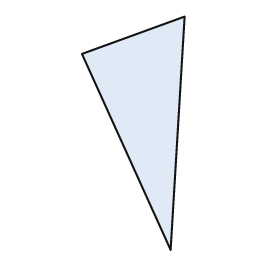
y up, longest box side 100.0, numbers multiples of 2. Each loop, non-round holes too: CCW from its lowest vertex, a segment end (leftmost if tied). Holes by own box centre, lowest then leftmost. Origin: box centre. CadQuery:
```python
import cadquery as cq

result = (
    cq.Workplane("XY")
    .moveTo(16.0, -50.0)
    .lineTo(22.0, 50.0)
    .lineTo(-22.0, 34.0)
    .close()
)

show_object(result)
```